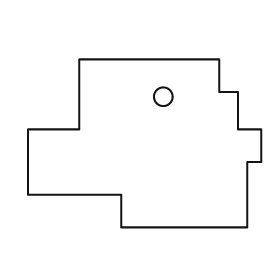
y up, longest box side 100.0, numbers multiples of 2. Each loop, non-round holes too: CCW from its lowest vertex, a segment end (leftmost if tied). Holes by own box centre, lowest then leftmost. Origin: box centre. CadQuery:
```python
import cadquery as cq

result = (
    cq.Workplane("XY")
    .moveTo(-10.0, -36.0)
    .lineTo(44.0, -36.0)
    .lineTo(44.0, -8.0)
    .lineTo(50.0, -8.0)
    .lineTo(50.0, 6.0)
    .lineTo(40.0, 6.0)
    .lineTo(40.0, 22.0)
    .lineTo(32.0, 22.0)
    .lineTo(32.0, 36.0)
    .lineTo(-28.0, 36.0)
    .lineTo(-28.0, 6.0)
    .lineTo(-50.0, 6.0)
    .lineTo(-50.0, -22.0)
    .lineTo(-10.0, -22.0)
    .close()
    .moveTo(8.0, 20.0)
    .circle(4.0)
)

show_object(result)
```